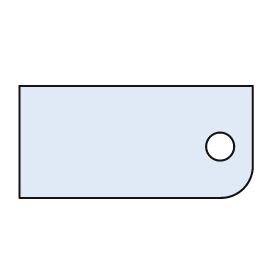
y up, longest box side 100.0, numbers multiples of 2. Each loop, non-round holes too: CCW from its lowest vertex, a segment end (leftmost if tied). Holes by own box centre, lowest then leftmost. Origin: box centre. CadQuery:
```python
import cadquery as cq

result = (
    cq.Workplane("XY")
    .moveTo(-50.0, -24.0)
    .lineTo(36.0, -24.0)
    .threePointArc((46.0, -20.0), (50.0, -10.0))
    .lineTo(50.0, 24.0)
    .lineTo(-50.0, 24.0)
    .close()
    .moveTo(36.0, -2.0)
    .circle(6.0)
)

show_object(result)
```